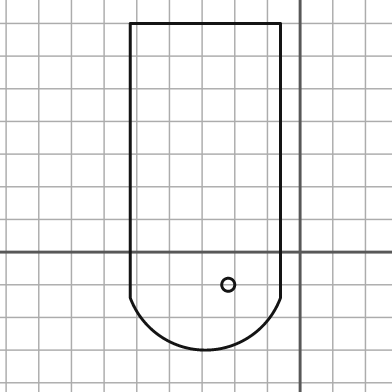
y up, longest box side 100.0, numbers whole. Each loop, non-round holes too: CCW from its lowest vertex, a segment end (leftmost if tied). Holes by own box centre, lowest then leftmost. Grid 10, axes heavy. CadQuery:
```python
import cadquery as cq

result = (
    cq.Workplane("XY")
    .moveTo(-52.0, -14.0)
    .threePointArc((-29.0, -30.0), (-6.0, -14.0))
    .lineTo(-6.0, 70.0)
    .lineTo(-52.0, 70.0)
    .close()
    .moveTo(-22.0, -10.0)
    .circle(2.0)
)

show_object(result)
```